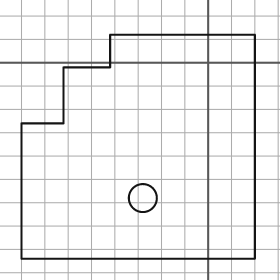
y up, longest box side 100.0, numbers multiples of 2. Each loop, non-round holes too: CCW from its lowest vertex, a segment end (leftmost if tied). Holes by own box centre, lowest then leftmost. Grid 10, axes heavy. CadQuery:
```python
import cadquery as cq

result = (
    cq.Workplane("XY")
    .moveTo(-80.0, -84.0)
    .lineTo(20.0, -84.0)
    .lineTo(20.0, 12.0)
    .lineTo(-42.0, 12.0)
    .lineTo(-42.0, -2.0)
    .lineTo(-62.0, -2.0)
    .lineTo(-62.0, -26.0)
    .lineTo(-80.0, -26.0)
    .close()
    .moveTo(-28.0, -58.0)
    .circle(6.0)
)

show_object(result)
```